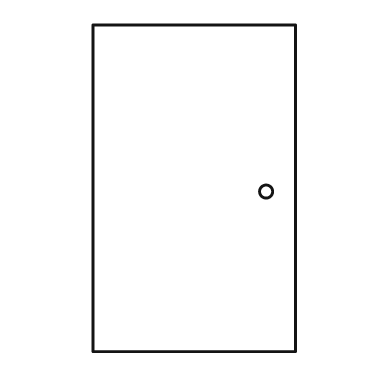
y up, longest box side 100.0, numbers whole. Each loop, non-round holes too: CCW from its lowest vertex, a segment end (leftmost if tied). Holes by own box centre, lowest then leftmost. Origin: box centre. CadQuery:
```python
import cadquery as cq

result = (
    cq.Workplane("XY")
    .moveTo(-31.0, -50.0)
    .lineTo(31.0, -50.0)
    .lineTo(31.0, 50.0)
    .lineTo(-31.0, 50.0)
    .close()
    .moveTo(22.0, -1.0)
    .circle(2.0)
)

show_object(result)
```